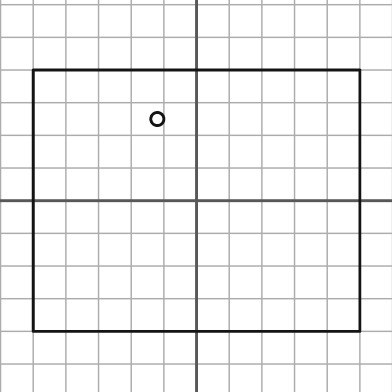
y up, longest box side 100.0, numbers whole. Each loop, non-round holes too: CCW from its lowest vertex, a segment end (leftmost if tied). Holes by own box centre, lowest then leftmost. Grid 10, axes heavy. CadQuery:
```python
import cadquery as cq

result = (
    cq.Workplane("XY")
    .moveTo(-50.0, -40.0)
    .lineTo(50.0, -40.0)
    .lineTo(50.0, 40.0)
    .lineTo(-50.0, 40.0)
    .close()
    .moveTo(-12.0, 25.0)
    .circle(2.0)
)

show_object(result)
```